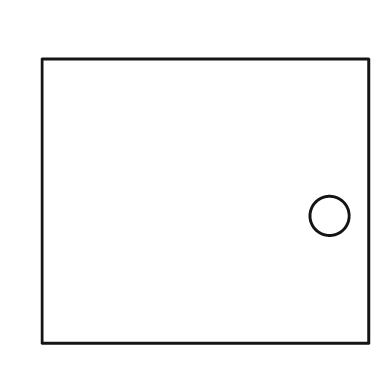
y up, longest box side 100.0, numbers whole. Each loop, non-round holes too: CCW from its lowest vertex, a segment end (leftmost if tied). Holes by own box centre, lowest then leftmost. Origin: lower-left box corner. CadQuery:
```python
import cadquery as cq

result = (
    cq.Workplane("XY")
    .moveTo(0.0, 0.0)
    .lineTo(100.0, 0.0)
    .lineTo(100.0, 87.0)
    .lineTo(0.0, 87.0)
    .close()
    .moveTo(88.0, 39.0)
    .circle(6.0)
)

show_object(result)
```